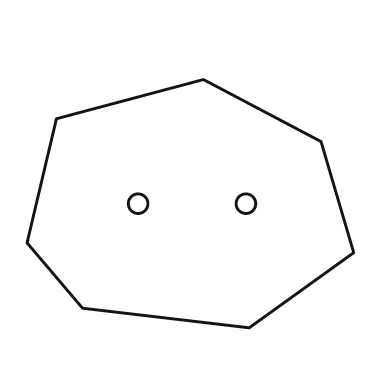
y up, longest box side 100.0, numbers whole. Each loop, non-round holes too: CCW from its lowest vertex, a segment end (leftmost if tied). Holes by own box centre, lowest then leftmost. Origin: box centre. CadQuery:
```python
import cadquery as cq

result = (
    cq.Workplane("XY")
    .moveTo(18.0, -38.0)
    .lineTo(50.0, -15.0)
    .lineTo(40.0, 19.0)
    .lineTo(4.0, 38.0)
    .lineTo(-41.0, 26.0)
    .lineTo(-50.0, -12.0)
    .lineTo(-33.0, -32.0)
    .close()
    .moveTo(-16.0, 0.0)
    .circle(3.0)
    .moveTo(17.0, 0.0)
    .circle(3.0)
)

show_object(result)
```